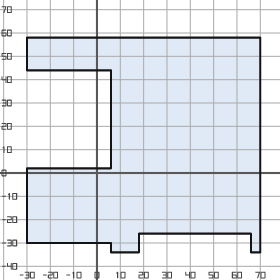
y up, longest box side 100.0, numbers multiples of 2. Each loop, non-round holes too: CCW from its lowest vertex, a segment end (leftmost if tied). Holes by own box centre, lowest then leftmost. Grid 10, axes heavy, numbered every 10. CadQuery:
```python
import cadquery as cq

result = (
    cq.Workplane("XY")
    .moveTo(6.0, -34.0)
    .lineTo(18.0, -34.0)
    .lineTo(18.0, -26.0)
    .lineTo(66.0, -26.0)
    .lineTo(66.0, -34.0)
    .lineTo(70.0, -34.0)
    .lineTo(70.0, 58.0)
    .lineTo(-30.0, 58.0)
    .lineTo(-30.0, 44.0)
    .lineTo(6.0, 44.0)
    .lineTo(6.0, 2.0)
    .lineTo(-30.0, 2.0)
    .lineTo(-30.0, -30.0)
    .lineTo(6.0, -30.0)
    .close()
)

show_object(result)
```